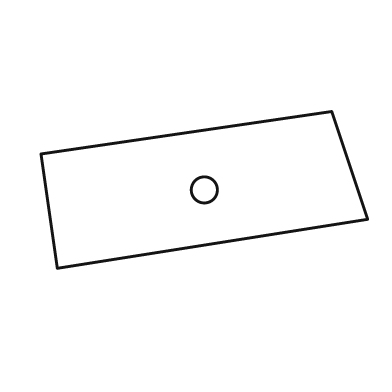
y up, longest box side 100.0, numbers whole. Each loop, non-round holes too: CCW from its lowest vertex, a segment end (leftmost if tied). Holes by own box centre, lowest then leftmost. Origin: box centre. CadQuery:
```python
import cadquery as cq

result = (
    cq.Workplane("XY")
    .moveTo(-45.0, -24.0)
    .lineTo(50.0, -9.0)
    .lineTo(39.0, 24.0)
    .lineTo(-50.0, 11.0)
    .close()
    .moveTo(0.0, 0.0)
    .circle(4.0)
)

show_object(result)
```